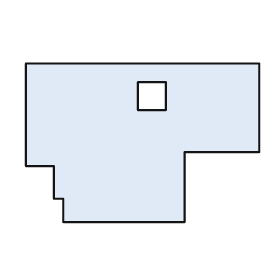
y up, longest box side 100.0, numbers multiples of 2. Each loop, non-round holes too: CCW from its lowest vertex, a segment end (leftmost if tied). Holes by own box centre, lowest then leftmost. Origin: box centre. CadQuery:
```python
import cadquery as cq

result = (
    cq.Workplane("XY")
    .moveTo(-34.0, -34.0)
    .lineTo(18.0, -34.0)
    .lineTo(18.0, -4.0)
    .lineTo(50.0, -4.0)
    .lineTo(50.0, 34.0)
    .lineTo(-50.0, 34.0)
    .lineTo(-50.0, -10.0)
    .lineTo(-38.0, -10.0)
    .lineTo(-38.0, -24.0)
    .lineTo(-34.0, -24.0)
    .close()
    .moveTo(-2.0, 14.0)
    .lineTo(10.0, 14.0)
    .lineTo(10.0, 26.0)
    .lineTo(-2.0, 26.0)
    .close()
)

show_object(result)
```